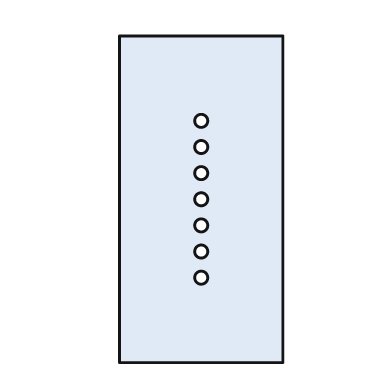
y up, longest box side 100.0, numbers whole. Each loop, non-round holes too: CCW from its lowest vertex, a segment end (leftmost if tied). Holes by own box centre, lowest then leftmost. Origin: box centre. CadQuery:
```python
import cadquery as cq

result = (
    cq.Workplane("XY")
    .moveTo(-25.0, -50.0)
    .lineTo(25.0, -50.0)
    .lineTo(25.0, 50.0)
    .lineTo(-25.0, 50.0)
    .close()
    .moveTo(0.0, -24.0)
    .circle(2.0)
    .moveTo(0.0, -16.0)
    .circle(2.0)
    .moveTo(0.0, -8.0)
    .circle(2.0)
    .moveTo(0.0, 0.0)
    .circle(2.0)
    .moveTo(0.0, 8.0)
    .circle(2.0)
    .moveTo(0.0, 16.0)
    .circle(2.0)
    .moveTo(0.0, 24.0)
    .circle(2.0)
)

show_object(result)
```